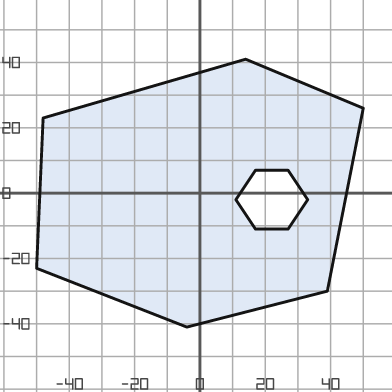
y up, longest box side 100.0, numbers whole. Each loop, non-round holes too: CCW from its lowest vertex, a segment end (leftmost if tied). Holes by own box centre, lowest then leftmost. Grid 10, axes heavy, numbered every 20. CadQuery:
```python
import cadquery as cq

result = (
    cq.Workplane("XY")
    .moveTo(-4.0, -41.0)
    .lineTo(39.0, -30.0)
    .lineTo(50.0, 26.0)
    .lineTo(14.0, 41.0)
    .lineTo(-48.0, 23.0)
    .lineTo(-50.0, -23.0)
    .close()
    .moveTo(17.0, -11.0)
    .lineTo(27.0, -11.0)
    .lineTo(33.0, -2.0)
    .lineTo(27.0, 7.0)
    .lineTo(17.0, 7.0)
    .lineTo(11.0, -2.0)
    .close()
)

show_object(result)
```